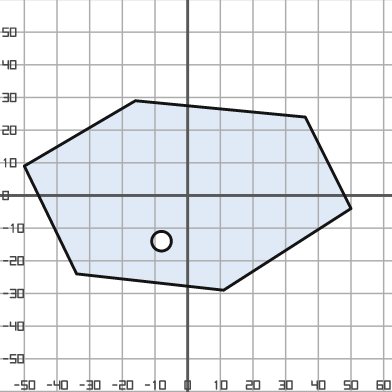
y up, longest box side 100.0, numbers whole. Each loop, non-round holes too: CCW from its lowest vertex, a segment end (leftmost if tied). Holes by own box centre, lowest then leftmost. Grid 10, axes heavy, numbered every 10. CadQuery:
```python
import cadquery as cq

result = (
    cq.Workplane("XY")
    .moveTo(11.0, -29.0)
    .lineTo(50.0, -4.0)
    .lineTo(36.0, 24.0)
    .lineTo(-16.0, 29.0)
    .lineTo(-50.0, 9.0)
    .lineTo(-34.0, -24.0)
    .close()
    .moveTo(-8.0, -14.0)
    .circle(3.0)
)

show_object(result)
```